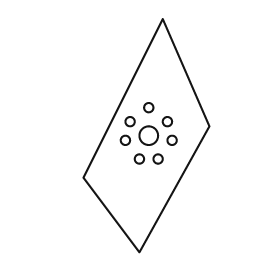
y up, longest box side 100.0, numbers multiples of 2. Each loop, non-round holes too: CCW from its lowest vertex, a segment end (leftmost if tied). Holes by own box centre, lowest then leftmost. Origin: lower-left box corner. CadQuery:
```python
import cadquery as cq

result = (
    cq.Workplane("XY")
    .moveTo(24.0, 0.0)
    .lineTo(54.0, 54.0)
    .lineTo(34.0, 100.0)
    .lineTo(0.0, 32.0)
    .close()
    .moveTo(24.0, 40.0)
    .circle(2.0)
    .moveTo(32.0, 40.0)
    .circle(2.0)
    .moveTo(18.0, 48.0)
    .circle(2.0)
    .moveTo(38.0, 48.0)
    .circle(2.0)
    .moveTo(28.0, 50.0)
    .circle(4.0)
    .moveTo(20.0, 56.0)
    .circle(2.0)
    .moveTo(36.0, 56.0)
    .circle(2.0)
    .moveTo(28.0, 62.0)
    .circle(2.0)
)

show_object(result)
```